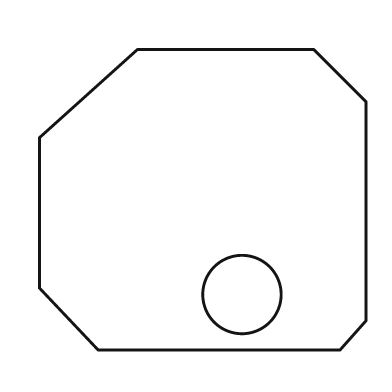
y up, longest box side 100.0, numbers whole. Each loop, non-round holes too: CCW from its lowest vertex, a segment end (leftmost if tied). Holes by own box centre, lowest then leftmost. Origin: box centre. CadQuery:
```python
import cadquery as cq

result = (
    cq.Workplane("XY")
    .moveTo(-32.0, -46.0)
    .lineTo(42.0, -46.0)
    .lineTo(50.0, -37.0)
    .lineTo(50.0, 30.0)
    .lineTo(34.0, 46.0)
    .lineTo(-20.0, 46.0)
    .lineTo(-50.0, 19.0)
    .lineTo(-50.0, -27.0)
    .close()
    .moveTo(12.0, -29.0)
    .circle(12.0)
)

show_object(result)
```